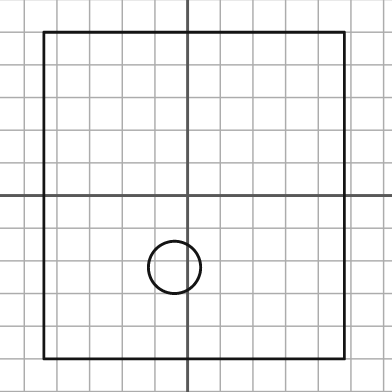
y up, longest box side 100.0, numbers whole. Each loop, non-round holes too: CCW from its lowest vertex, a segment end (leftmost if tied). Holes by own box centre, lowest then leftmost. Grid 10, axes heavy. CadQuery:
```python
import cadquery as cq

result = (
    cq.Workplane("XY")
    .moveTo(-44.0, -50.0)
    .lineTo(48.0, -50.0)
    .lineTo(48.0, 50.0)
    .lineTo(-44.0, 50.0)
    .close()
    .moveTo(-4.0, -22.0)
    .circle(8.0)
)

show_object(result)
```